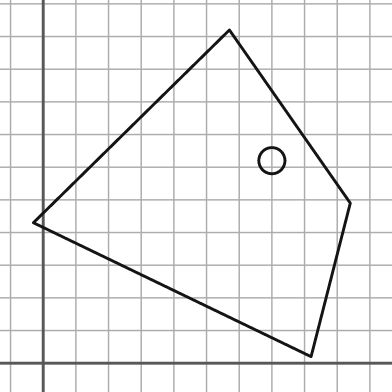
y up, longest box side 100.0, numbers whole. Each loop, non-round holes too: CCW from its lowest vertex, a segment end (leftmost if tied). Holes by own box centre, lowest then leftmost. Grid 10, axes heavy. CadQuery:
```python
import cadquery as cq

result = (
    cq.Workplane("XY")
    .moveTo(82.0, 2.0)
    .lineTo(94.0, 49.0)
    .lineTo(57.0, 102.0)
    .lineTo(-3.0, 43.0)
    .close()
    .moveTo(70.0, 62.0)
    .circle(4.0)
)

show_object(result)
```